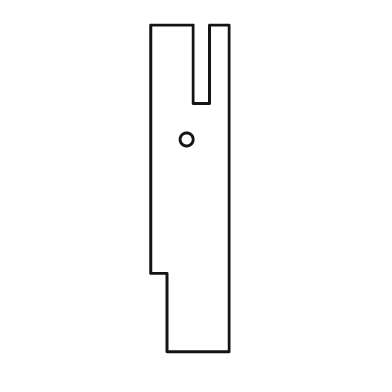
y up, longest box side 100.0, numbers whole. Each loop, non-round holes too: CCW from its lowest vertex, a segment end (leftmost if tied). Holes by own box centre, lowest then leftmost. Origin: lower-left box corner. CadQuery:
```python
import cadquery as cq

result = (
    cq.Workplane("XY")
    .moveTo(5.0, 0.0)
    .lineTo(24.0, 0.0)
    .lineTo(24.0, 100.0)
    .lineTo(18.0, 100.0)
    .lineTo(18.0, 76.0)
    .lineTo(13.0, 76.0)
    .lineTo(13.0, 100.0)
    .lineTo(0.0, 100.0)
    .lineTo(0.0, 24.0)
    .lineTo(5.0, 24.0)
    .close()
    .moveTo(11.0, 65.0)
    .circle(2.0)
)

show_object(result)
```